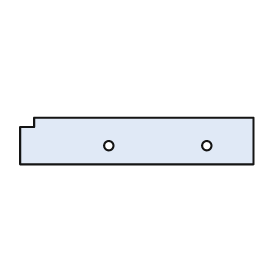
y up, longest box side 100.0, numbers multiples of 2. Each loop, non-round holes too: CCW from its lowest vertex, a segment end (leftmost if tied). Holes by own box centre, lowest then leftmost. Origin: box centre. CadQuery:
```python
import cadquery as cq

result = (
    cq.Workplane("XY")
    .moveTo(-50.0, -10.0)
    .lineTo(50.0, -10.0)
    .lineTo(50.0, 10.0)
    .lineTo(-44.0, 10.0)
    .lineTo(-44.0, 6.0)
    .lineTo(-50.0, 6.0)
    .close()
    .moveTo(-12.0, -2.0)
    .circle(2.0)
    .moveTo(30.0, -2.0)
    .circle(2.0)
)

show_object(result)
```